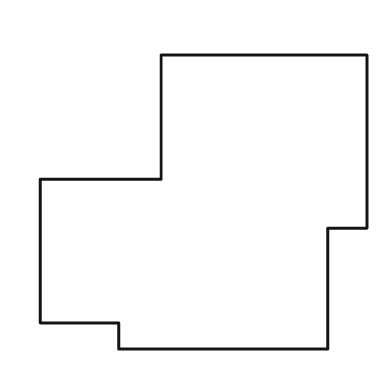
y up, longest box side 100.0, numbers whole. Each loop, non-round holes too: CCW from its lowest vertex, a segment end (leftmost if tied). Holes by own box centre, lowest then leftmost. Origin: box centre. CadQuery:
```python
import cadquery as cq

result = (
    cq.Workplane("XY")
    .moveTo(-26.0, -45.0)
    .lineTo(38.0, -45.0)
    .lineTo(38.0, -8.0)
    .lineTo(50.0, -8.0)
    .lineTo(50.0, 45.0)
    .lineTo(-13.0, 45.0)
    .lineTo(-13.0, 7.0)
    .lineTo(-50.0, 7.0)
    .lineTo(-50.0, -37.0)
    .lineTo(-26.0, -37.0)
    .close()
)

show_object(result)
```